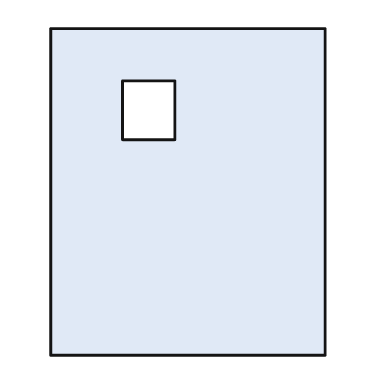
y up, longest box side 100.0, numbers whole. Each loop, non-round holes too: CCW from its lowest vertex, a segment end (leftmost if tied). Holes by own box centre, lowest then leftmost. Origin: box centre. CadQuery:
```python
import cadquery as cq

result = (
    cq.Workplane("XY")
    .moveTo(-42.0, -50.0)
    .lineTo(42.0, -50.0)
    .lineTo(42.0, 50.0)
    .lineTo(-42.0, 50.0)
    .close()
    .moveTo(-20.0, 16.0)
    .lineTo(-4.0, 16.0)
    .lineTo(-4.0, 34.0)
    .lineTo(-20.0, 34.0)
    .close()
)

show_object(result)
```